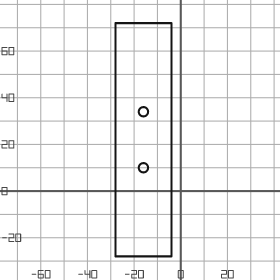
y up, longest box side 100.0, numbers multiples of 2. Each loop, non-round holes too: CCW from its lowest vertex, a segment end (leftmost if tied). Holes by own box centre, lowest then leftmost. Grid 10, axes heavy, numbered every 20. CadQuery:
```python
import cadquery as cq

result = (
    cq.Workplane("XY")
    .moveTo(-28.0, -28.0)
    .lineTo(-4.0, -28.0)
    .lineTo(-4.0, 72.0)
    .lineTo(-28.0, 72.0)
    .close()
    .moveTo(-16.0, 10.0)
    .circle(2.0)
    .moveTo(-16.0, 34.0)
    .circle(2.0)
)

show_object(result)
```